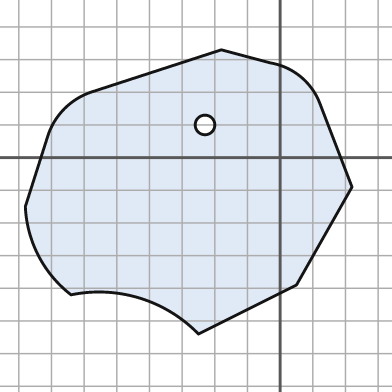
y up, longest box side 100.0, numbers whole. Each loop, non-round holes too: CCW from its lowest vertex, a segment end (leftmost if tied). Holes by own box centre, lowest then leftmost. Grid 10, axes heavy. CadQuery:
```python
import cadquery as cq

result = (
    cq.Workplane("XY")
    .moveTo(-25.0, -54.0)
    .lineTo(5.0, -39.0)
    .lineTo(22.0, -9.0)
    .lineTo(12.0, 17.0)
    .threePointArc((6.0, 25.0), (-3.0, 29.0))
    .lineTo(-18.0, 33.0)
    .lineTo(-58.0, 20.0)
    .threePointArc((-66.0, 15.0), (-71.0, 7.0))
    .lineTo(-78.0, -15.0)
    .threePointArc((-74.0, -30.0), (-64.0, -42.0))
    .threePointArc((-43.0, -43.0), (-25.0, -54.0))
    .close()
    .moveTo(-23.0, 10.0)
    .circle(3.0)
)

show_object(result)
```